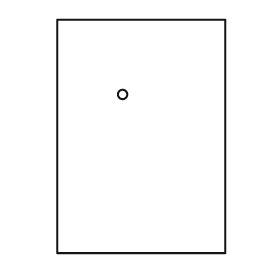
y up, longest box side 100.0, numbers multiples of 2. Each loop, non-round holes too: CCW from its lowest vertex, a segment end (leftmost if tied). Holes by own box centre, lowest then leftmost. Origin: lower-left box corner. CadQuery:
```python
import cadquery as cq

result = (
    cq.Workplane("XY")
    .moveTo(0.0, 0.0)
    .lineTo(72.0, 0.0)
    .lineTo(72.0, 100.0)
    .lineTo(0.0, 100.0)
    .close()
    .moveTo(28.0, 68.0)
    .circle(2.0)
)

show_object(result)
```